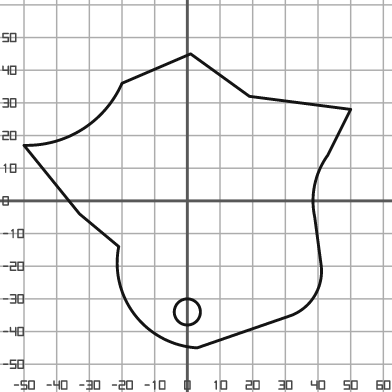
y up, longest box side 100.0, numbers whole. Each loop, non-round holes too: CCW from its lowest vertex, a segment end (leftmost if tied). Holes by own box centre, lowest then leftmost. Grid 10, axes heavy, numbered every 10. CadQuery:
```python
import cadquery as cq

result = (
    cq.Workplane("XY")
    .moveTo(3.0, -45.0)
    .lineTo(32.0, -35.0)
    .threePointArc((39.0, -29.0), (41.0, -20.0))
    .lineTo(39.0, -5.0)
    .threePointArc((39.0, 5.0), (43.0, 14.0))
    .lineTo(50.0, 28.0)
    .lineTo(19.0, 32.0)
    .lineTo(1.0, 45.0)
    .lineTo(-20.0, 36.0)
    .threePointArc((-32.0, 22.0), (-50.0, 17.0))
    .lineTo(-33.0, -4.0)
    .lineTo(-21.0, -14.0)
    .threePointArc((-16.0, -35.0), (3.0, -45.0))
    .close()
    .moveTo(0.0, -34.0)
    .circle(4.0)
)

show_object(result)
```